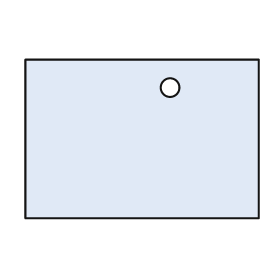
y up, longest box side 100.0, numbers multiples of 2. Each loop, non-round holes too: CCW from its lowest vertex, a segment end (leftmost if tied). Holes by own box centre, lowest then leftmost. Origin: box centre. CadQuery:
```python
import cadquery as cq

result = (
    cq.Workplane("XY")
    .moveTo(-50.0, -34.0)
    .lineTo(50.0, -34.0)
    .lineTo(50.0, 34.0)
    .lineTo(-50.0, 34.0)
    .close()
    .moveTo(12.0, 22.0)
    .circle(4.0)
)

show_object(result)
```